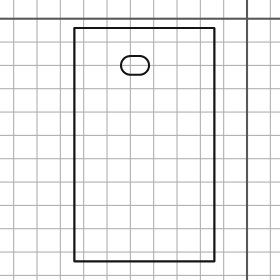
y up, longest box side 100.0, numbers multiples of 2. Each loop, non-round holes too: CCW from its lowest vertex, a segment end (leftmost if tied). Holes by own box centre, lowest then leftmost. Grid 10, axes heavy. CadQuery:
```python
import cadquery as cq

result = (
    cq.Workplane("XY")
    .moveTo(-74.0, -104.0)
    .lineTo(-14.0, -104.0)
    .lineTo(-14.0, -4.0)
    .lineTo(-74.0, -4.0)
    .close()
    .moveTo(-50.0, -24.0)
    .lineTo(-46.0, -24.0)
    .threePointArc((-42.0, -20.0), (-46.0, -16.0))
    .lineTo(-50.0, -16.0)
    .threePointArc((-54.0, -20.0), (-50.0, -24.0))
    .close()
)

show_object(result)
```